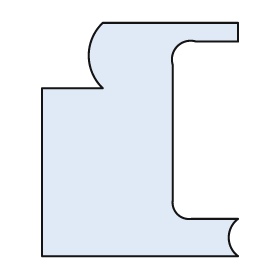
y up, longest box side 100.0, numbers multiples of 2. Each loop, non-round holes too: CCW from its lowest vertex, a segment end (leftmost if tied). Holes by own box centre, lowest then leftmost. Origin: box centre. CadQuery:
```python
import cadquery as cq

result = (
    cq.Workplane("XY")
    .moveTo(-42.0, -50.0)
    .lineTo(42.0, -50.0)
    .threePointArc((38.0, -42.0), (42.0, -34.0))
    .lineTo(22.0, -34.0)
    .threePointArc((16.0, -32.0), (14.0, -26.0))
    .lineTo(14.0, 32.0)
    .threePointArc((16.0, 40.0), (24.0, 42.0))
    .lineTo(42.0, 42.0)
    .lineTo(42.0, 50.0)
    .lineTo(-16.0, 50.0)
    .threePointArc((-22.0, 36.0), (-16.0, 22.0))
    .lineTo(-42.0, 22.0)
    .close()
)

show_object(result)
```